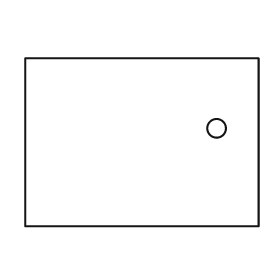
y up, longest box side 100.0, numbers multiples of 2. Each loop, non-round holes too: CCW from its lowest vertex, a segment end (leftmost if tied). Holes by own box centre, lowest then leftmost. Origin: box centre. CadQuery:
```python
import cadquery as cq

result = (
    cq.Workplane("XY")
    .moveTo(-50.0, -36.0)
    .lineTo(50.0, -36.0)
    .lineTo(50.0, 36.0)
    .lineTo(-50.0, 36.0)
    .close()
    .moveTo(32.0, 6.0)
    .circle(4.0)
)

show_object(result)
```